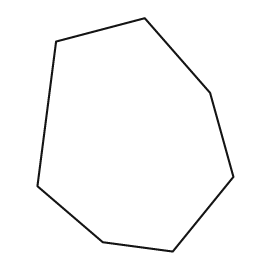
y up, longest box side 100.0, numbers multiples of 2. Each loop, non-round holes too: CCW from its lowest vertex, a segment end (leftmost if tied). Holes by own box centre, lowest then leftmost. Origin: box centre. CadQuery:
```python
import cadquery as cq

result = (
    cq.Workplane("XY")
    .moveTo(16.0, -50.0)
    .lineTo(42.0, -18.0)
    .lineTo(32.0, 18.0)
    .lineTo(4.0, 50.0)
    .lineTo(-34.0, 40.0)
    .lineTo(-42.0, -22.0)
    .lineTo(-14.0, -46.0)
    .close()
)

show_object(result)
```